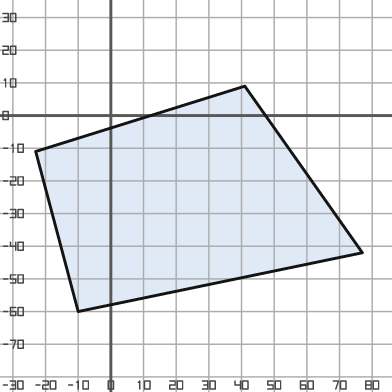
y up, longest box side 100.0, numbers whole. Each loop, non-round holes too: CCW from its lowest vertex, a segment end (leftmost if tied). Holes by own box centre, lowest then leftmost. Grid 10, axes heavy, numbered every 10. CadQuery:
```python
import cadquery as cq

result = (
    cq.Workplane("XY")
    .moveTo(-10.0, -60.0)
    .lineTo(77.0, -42.0)
    .lineTo(41.0, 9.0)
    .lineTo(-23.0, -11.0)
    .close()
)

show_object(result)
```